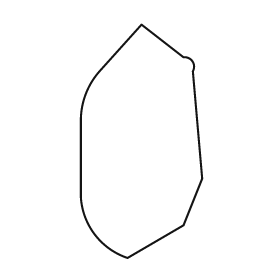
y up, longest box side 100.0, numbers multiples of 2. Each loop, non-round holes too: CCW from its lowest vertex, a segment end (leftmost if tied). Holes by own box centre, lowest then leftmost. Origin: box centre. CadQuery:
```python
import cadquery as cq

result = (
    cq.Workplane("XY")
    .moveTo(-6.0, -50.0)
    .lineTo(18.0, -36.0)
    .lineTo(26.0, -16.0)
    .lineTo(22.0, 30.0)
    .threePointArc((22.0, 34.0), (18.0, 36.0))
    .lineTo(0.0, 50.0)
    .lineTo(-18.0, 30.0)
    .threePointArc((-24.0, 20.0), (-26.0, 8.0))
    .lineTo(-26.0, -24.0)
    .threePointArc((-20.0, -40.0), (-6.0, -50.0))
    .close()
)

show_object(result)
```